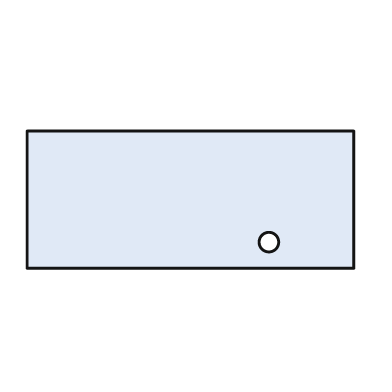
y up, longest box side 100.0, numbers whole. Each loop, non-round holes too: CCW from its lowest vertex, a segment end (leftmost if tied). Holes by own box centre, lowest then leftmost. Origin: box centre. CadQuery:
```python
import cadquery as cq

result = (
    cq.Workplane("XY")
    .moveTo(-50.0, -21.0)
    .lineTo(50.0, -21.0)
    .lineTo(50.0, 21.0)
    .lineTo(-50.0, 21.0)
    .close()
    .moveTo(24.0, -13.0)
    .circle(3.0)
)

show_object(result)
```